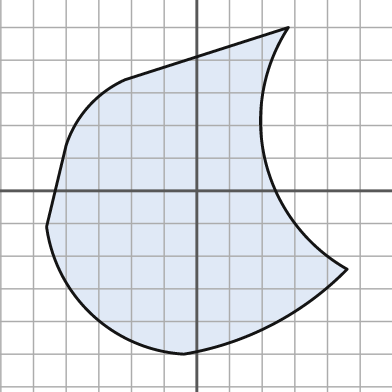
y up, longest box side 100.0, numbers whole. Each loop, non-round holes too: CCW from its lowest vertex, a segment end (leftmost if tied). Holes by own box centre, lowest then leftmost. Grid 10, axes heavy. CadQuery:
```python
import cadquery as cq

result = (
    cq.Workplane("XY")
    .moveTo(-4.0, -50.0)
    .threePointArc((23.0, -41.0), (46.0, -24.0))
    .threePointArc((21.0, 9.0), (28.0, 50.0))
    .lineTo(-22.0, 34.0)
    .threePointArc((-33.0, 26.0), (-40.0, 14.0))
    .lineTo(-46.0, -11.0)
    .threePointArc((-32.0, -38.0), (-4.0, -50.0))
    .close()
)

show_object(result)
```